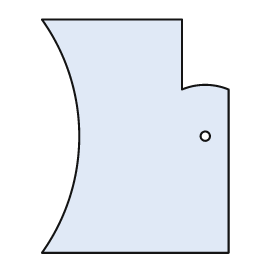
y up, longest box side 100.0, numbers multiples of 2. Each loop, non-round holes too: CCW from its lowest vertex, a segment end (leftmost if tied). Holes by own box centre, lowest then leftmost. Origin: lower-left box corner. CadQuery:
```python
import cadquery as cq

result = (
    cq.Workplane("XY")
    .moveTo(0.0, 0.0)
    .lineTo(80.0, 0.0)
    .lineTo(80.0, 70.0)
    .threePointArc((70.0, 72.0), (60.0, 70.0))
    .lineTo(60.0, 100.0)
    .lineTo(0.0, 100.0)
    .threePointArc((16.0, 50.0), (0.0, 0.0))
    .close()
    .moveTo(70.0, 50.0)
    .circle(2.0)
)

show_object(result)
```